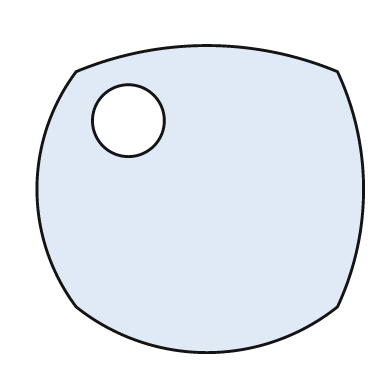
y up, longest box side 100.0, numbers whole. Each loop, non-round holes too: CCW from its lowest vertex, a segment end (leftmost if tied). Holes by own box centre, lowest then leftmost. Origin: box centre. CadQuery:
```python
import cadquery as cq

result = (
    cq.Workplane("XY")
    .moveTo(-38.0, -33.0)
    .threePointArc((2.0, -47.0), (42.0, -33.0))
    .threePointArc((50.0, 3.0), (42.0, 39.0))
    .threePointArc((2.0, 47.0), (-38.0, 39.0))
    .threePointArc((-50.0, 3.0), (-38.0, -33.0))
    .close()
    .moveTo(-22.0, 24.0)
    .circle(11.0)
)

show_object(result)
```